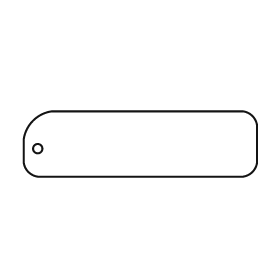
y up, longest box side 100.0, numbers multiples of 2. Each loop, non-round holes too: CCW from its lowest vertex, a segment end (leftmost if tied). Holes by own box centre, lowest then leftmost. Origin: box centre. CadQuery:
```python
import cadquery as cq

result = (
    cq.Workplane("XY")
    .moveTo(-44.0, -14.0)
    .lineTo(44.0, -14.0)
    .threePointArc((48.0, -12.0), (50.0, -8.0))
    .lineTo(50.0, 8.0)
    .threePointArc((48.0, 12.0), (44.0, 14.0))
    .lineTo(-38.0, 14.0)
    .threePointArc((-46.0, 10.0), (-50.0, 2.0))
    .lineTo(-50.0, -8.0)
    .threePointArc((-48.0, -12.0), (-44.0, -14.0))
    .close()
    .moveTo(-44.0, -2.0)
    .circle(2.0)
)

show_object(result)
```